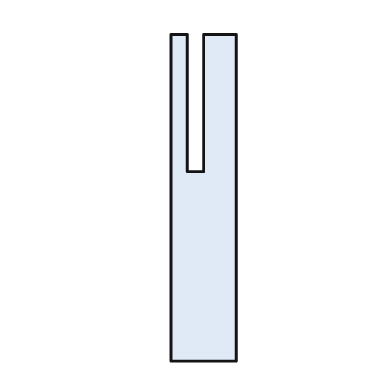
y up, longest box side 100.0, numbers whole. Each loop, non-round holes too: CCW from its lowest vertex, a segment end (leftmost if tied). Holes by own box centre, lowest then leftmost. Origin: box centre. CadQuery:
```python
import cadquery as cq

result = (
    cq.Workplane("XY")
    .moveTo(-10.0, -50.0)
    .lineTo(10.0, -50.0)
    .lineTo(10.0, 50.0)
    .lineTo(0.0, 50.0)
    .lineTo(0.0, 8.0)
    .lineTo(-5.0, 8.0)
    .lineTo(-5.0, 50.0)
    .lineTo(-10.0, 50.0)
    .close()
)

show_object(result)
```